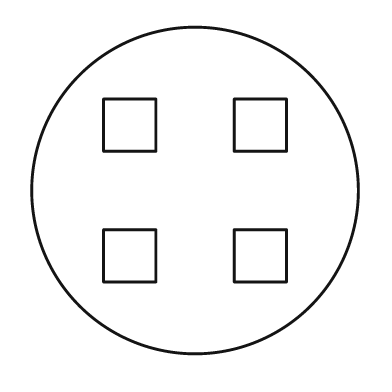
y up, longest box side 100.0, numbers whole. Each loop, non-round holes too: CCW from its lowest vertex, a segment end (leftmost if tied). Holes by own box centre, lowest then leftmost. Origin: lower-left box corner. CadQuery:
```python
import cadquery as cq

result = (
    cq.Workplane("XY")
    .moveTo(50.0, 50.0)
    .circle(50.0)
    .moveTo(22.0, 22.0)
    .lineTo(38.0, 22.0)
    .lineTo(38.0, 38.0)
    .lineTo(22.0, 38.0)
    .close()
    .moveTo(62.0, 22.0)
    .lineTo(78.0, 22.0)
    .lineTo(78.0, 38.0)
    .lineTo(62.0, 38.0)
    .close()
    .moveTo(22.0, 62.0)
    .lineTo(38.0, 62.0)
    .lineTo(38.0, 78.0)
    .lineTo(22.0, 78.0)
    .close()
    .moveTo(62.0, 62.0)
    .lineTo(78.0, 62.0)
    .lineTo(78.0, 78.0)
    .lineTo(62.0, 78.0)
    .close()
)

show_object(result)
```